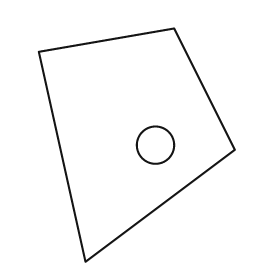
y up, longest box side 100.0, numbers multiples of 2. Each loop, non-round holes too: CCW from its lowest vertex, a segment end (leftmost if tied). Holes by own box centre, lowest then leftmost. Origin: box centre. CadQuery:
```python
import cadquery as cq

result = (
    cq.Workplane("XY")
    .moveTo(-22.0, -50.0)
    .lineTo(42.0, -2.0)
    .lineTo(16.0, 50.0)
    .lineTo(-42.0, 40.0)
    .close()
    .moveTo(8.0, 0.0)
    .circle(8.0)
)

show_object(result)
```